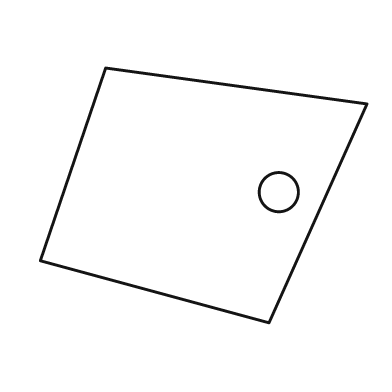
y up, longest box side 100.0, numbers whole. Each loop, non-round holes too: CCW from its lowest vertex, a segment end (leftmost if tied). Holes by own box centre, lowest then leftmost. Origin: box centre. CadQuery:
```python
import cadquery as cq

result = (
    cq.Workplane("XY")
    .moveTo(20.0, -39.0)
    .lineTo(50.0, 28.0)
    .lineTo(-30.0, 39.0)
    .lineTo(-50.0, -20.0)
    .close()
    .moveTo(23.0, 1.0)
    .circle(6.0)
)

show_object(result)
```